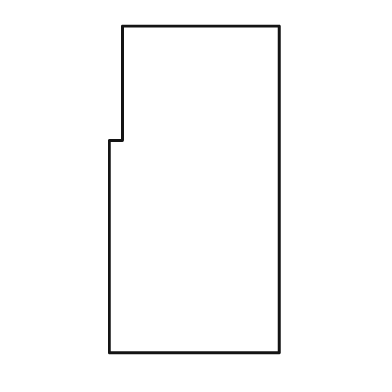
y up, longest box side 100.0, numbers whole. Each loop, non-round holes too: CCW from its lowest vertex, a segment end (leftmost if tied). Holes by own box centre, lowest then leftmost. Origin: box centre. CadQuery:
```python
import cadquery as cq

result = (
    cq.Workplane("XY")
    .moveTo(-26.0, -50.0)
    .lineTo(26.0, -50.0)
    .lineTo(26.0, 50.0)
    .lineTo(-22.0, 50.0)
    .lineTo(-22.0, 15.0)
    .lineTo(-26.0, 15.0)
    .close()
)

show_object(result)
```